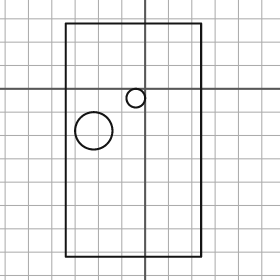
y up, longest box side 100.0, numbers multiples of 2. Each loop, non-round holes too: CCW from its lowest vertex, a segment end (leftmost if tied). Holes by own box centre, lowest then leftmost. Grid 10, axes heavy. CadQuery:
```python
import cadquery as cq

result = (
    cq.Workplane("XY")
    .moveTo(-34.0, -72.0)
    .lineTo(24.0, -72.0)
    .lineTo(24.0, 28.0)
    .lineTo(-34.0, 28.0)
    .close()
    .moveTo(-22.0, -18.0)
    .circle(8.0)
    .moveTo(-4.0, -4.0)
    .circle(4.0)
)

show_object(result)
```